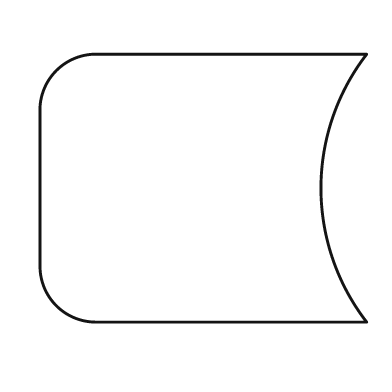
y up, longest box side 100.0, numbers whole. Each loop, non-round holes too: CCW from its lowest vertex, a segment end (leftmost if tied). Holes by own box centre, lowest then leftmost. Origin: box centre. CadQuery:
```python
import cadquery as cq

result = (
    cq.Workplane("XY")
    .moveTo(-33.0, -41.0)
    .lineTo(50.0, -41.0)
    .threePointArc((36.0, 0.0), (50.0, 41.0))
    .lineTo(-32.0, 41.0)
    .threePointArc((-45.0, 36.0), (-50.0, 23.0))
    .lineTo(-50.0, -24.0)
    .threePointArc((-45.0, -36.0), (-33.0, -41.0))
    .close()
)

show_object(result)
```